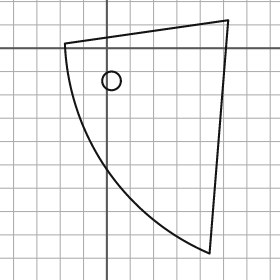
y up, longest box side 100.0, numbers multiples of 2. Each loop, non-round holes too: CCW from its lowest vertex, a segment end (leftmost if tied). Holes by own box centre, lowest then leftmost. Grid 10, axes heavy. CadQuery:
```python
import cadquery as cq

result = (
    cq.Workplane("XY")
    .moveTo(44.0, -88.0)
    .lineTo(52.0, 12.0)
    .lineTo(-18.0, 2.0)
    .threePointArc((0.0, -52.0), (44.0, -88.0))
    .close()
    .moveTo(2.0, -14.0)
    .circle(4.0)
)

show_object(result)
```